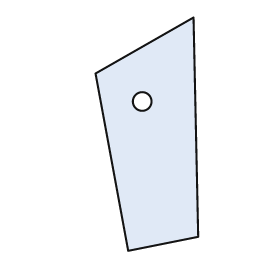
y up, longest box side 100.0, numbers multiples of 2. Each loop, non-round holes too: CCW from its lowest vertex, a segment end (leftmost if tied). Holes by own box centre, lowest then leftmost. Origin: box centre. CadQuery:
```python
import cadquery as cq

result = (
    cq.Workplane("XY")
    .moveTo(-8.0, -50.0)
    .lineTo(22.0, -44.0)
    .lineTo(20.0, 50.0)
    .lineTo(-22.0, 26.0)
    .close()
    .moveTo(-2.0, 14.0)
    .circle(4.0)
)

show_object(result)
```